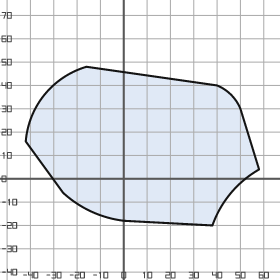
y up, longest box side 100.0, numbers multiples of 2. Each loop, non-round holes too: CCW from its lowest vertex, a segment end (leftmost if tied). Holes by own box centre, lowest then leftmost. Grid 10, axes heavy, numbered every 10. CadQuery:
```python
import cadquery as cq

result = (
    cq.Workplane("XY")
    .moveTo(38.0, -20.0)
    .threePointArc((46.0, -6.0), (58.0, 4.0))
    .lineTo(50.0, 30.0)
    .threePointArc((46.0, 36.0), (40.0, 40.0))
    .lineTo(-16.0, 48.0)
    .threePointArc((-34.0, 36.0), (-42.0, 16.0))
    .lineTo(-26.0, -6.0)
    .threePointArc((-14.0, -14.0), (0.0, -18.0))
    .close()
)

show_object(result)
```